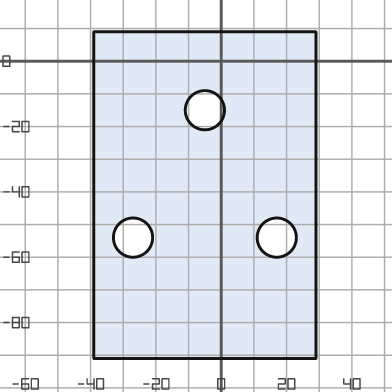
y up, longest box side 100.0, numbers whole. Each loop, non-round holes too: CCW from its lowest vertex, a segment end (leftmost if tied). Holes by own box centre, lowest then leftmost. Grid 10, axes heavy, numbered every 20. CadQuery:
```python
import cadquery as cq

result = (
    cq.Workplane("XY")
    .moveTo(-39.0, -91.0)
    .lineTo(29.0, -91.0)
    .lineTo(29.0, 9.0)
    .lineTo(-39.0, 9.0)
    .close()
    .moveTo(-27.0, -54.0)
    .circle(6.0)
    .moveTo(17.0, -54.0)
    .circle(6.0)
    .moveTo(-5.0, -15.0)
    .circle(6.0)
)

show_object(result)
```